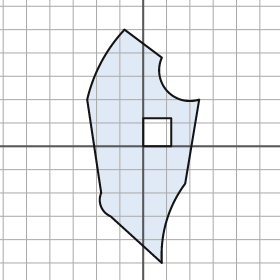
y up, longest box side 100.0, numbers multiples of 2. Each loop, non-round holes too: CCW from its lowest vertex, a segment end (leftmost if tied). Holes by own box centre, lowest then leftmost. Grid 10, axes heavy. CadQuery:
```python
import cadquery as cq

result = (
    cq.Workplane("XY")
    .moveTo(8.0, -50.0)
    .threePointArc((10.0, -32.0), (18.0, -16.0))
    .lineTo(24.0, 20.0)
    .threePointArc((10.0, 24.0), (8.0, 38.0))
    .lineTo(-8.0, 50.0)
    .threePointArc((-18.0, 36.0), (-24.0, 20.0))
    .lineTo(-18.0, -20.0)
    .threePointArc((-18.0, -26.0), (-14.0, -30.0))
    .close()
    .moveTo(0.0, 0.0)
    .lineTo(12.0, 0.0)
    .lineTo(12.0, 12.0)
    .lineTo(0.0, 12.0)
    .close()
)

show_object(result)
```